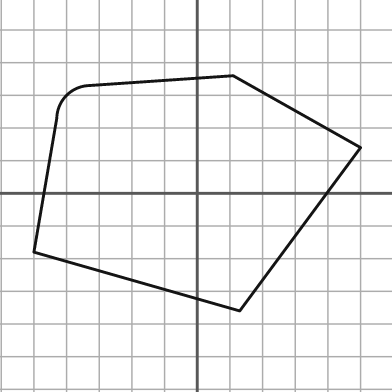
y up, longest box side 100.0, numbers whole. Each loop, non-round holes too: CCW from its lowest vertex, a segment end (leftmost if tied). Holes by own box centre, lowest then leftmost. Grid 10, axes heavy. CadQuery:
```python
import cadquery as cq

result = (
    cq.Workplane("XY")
    .moveTo(13.0, -36.0)
    .lineTo(50.0, 14.0)
    .lineTo(11.0, 36.0)
    .lineTo(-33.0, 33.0)
    .threePointArc((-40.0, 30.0), (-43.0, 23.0))
    .lineTo(-50.0, -18.0)
    .close()
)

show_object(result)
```